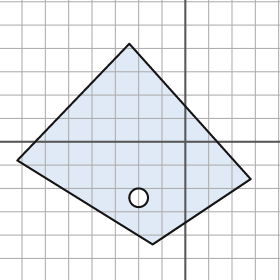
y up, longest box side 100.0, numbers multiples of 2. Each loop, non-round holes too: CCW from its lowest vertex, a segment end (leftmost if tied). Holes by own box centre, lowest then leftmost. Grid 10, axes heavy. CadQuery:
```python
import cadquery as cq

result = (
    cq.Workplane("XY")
    .moveTo(-14.0, -44.0)
    .lineTo(28.0, -16.0)
    .lineTo(-24.0, 42.0)
    .lineTo(-72.0, -8.0)
    .close()
    .moveTo(-20.0, -24.0)
    .circle(4.0)
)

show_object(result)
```